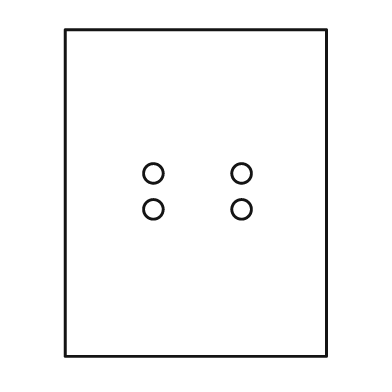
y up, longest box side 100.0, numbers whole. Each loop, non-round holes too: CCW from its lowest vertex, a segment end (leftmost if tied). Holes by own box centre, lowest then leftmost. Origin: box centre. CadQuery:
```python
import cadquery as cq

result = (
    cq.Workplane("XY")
    .moveTo(-40.0, -50.0)
    .lineTo(40.0, -50.0)
    .lineTo(40.0, 50.0)
    .lineTo(-40.0, 50.0)
    .close()
    .moveTo(-13.0, -5.0)
    .circle(3.0)
    .moveTo(14.0, -5.0)
    .circle(3.0)
    .moveTo(-13.0, 6.0)
    .circle(3.0)
    .moveTo(14.0, 6.0)
    .circle(3.0)
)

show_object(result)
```